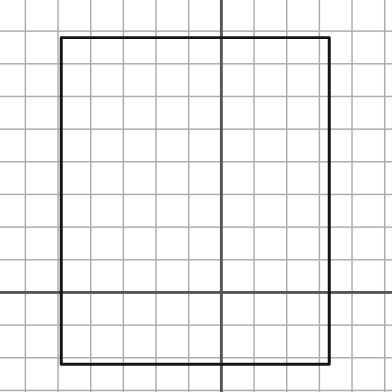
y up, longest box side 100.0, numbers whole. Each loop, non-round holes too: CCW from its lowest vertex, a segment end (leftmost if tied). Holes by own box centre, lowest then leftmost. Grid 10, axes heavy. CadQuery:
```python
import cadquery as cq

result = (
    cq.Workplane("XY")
    .moveTo(-49.0, -22.0)
    .lineTo(33.0, -22.0)
    .lineTo(33.0, 78.0)
    .lineTo(-49.0, 78.0)
    .close()
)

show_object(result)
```